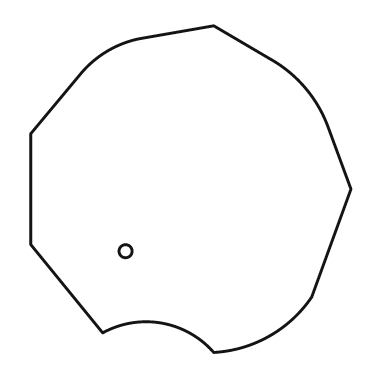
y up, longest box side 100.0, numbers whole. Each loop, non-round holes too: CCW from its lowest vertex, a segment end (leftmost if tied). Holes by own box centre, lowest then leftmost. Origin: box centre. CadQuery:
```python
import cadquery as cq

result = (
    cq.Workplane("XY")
    .moveTo(7.0, -50.0)
    .threePointArc((24.0, -45.0), (37.0, -33.0))
    .lineTo(49.0, 0.0)
    .lineTo(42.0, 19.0)
    .threePointArc((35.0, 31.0), (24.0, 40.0))
    .lineTo(7.0, 50.0)
    .lineTo(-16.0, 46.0)
    .threePointArc((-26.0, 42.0), (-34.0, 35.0))
    .lineTo(-49.0, 17.0)
    .lineTo(-49.0, -17.0)
    .lineTo(-27.0, -44.0)
    .threePointArc((-9.0, -41.0), (7.0, -50.0))
    .close()
    .moveTo(-20.0, -19.0)
    .circle(2.0)
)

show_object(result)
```